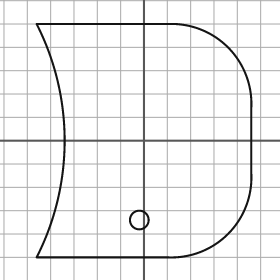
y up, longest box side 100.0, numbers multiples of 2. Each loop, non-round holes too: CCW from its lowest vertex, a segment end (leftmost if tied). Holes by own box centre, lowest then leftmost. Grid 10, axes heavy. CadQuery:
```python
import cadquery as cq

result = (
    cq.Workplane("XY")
    .moveTo(-46.0, -50.0)
    .lineTo(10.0, -50.0)
    .threePointArc((36.0, -40.0), (46.0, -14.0))
    .lineTo(46.0, 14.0)
    .threePointArc((36.0, 40.0), (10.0, 50.0))
    .lineTo(-46.0, 50.0)
    .threePointArc((-34.0, 0.0), (-46.0, -50.0))
    .close()
    .moveTo(-2.0, -34.0)
    .circle(4.0)
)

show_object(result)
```